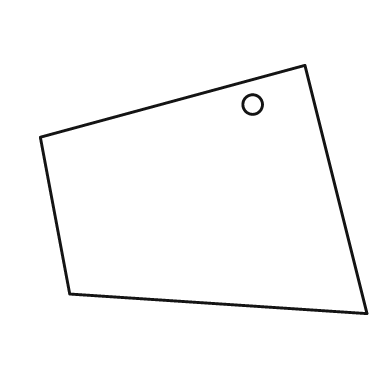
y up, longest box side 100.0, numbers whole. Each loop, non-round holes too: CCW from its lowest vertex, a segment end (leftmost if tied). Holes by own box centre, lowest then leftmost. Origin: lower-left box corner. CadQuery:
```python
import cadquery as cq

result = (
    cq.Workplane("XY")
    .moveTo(100.0, 0.0)
    .lineTo(81.0, 76.0)
    .lineTo(0.0, 54.0)
    .lineTo(9.0, 6.0)
    .close()
    .moveTo(65.0, 64.0)
    .circle(3.0)
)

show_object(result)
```